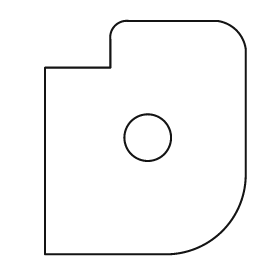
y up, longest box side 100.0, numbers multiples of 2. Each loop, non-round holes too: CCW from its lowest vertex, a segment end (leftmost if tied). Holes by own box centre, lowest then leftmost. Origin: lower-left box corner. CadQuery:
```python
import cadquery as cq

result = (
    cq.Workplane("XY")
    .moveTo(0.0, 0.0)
    .lineTo(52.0, 0.0)
    .threePointArc((76.0, 10.0), (86.0, 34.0))
    .lineTo(86.0, 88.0)
    .threePointArc((82.0, 96.0), (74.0, 100.0))
    .lineTo(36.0, 100.0)
    .threePointArc((30.0, 98.0), (28.0, 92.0))
    .lineTo(28.0, 80.0)
    .lineTo(0.0, 80.0)
    .close()
    .moveTo(44.0, 50.0)
    .circle(10.0)
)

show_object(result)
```